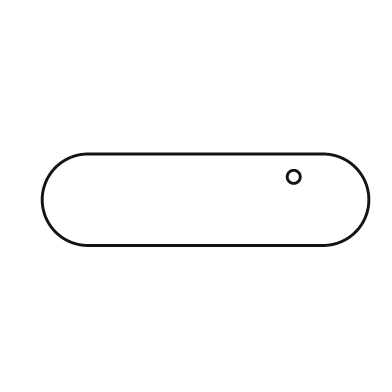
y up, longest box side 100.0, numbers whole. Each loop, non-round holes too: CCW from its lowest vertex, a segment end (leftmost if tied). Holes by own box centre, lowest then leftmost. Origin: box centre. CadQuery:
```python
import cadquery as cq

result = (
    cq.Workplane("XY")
    .moveTo(-36.0, -14.0)
    .lineTo(36.0, -14.0)
    .threePointArc((50.0, 0.0), (36.0, 14.0))
    .lineTo(-36.0, 14.0)
    .threePointArc((-50.0, 0.0), (-36.0, -14.0))
    .close()
    .moveTo(27.0, 7.0)
    .circle(2.0)
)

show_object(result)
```